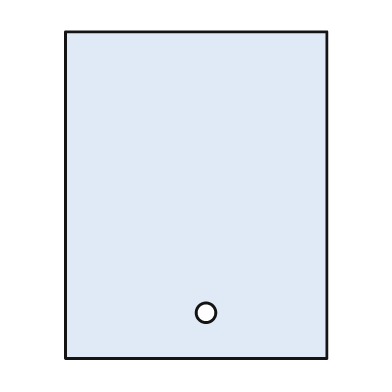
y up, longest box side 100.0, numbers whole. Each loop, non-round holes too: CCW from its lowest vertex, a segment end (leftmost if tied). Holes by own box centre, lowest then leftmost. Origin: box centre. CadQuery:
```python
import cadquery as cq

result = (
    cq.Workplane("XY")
    .moveTo(-40.0, -50.0)
    .lineTo(40.0, -50.0)
    .lineTo(40.0, 50.0)
    .lineTo(-40.0, 50.0)
    .close()
    .moveTo(3.0, -36.0)
    .circle(3.0)
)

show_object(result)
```